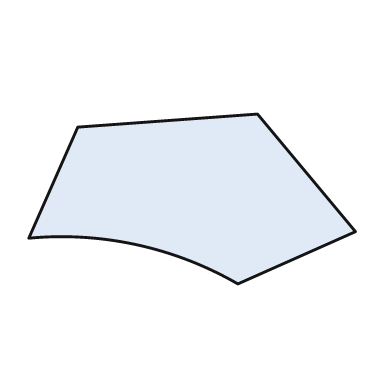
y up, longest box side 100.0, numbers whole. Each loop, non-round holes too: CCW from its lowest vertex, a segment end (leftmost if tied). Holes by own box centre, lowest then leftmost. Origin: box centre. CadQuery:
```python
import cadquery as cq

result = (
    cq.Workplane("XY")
    .moveTo(14.0, -26.0)
    .lineTo(50.0, -10.0)
    .lineTo(20.0, 26.0)
    .lineTo(-35.0, 22.0)
    .lineTo(-50.0, -12.0)
    .threePointArc((-17.0, -14.0), (14.0, -26.0))
    .close()
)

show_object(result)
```